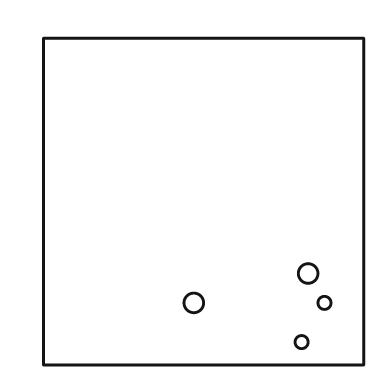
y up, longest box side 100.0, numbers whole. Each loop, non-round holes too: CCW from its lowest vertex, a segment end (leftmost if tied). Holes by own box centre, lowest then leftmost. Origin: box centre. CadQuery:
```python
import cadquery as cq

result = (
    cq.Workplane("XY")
    .moveTo(-49.0, -50.0)
    .lineTo(49.0, -50.0)
    .lineTo(49.0, 50.0)
    .lineTo(-49.0, 50.0)
    .close()
    .moveTo(30.0, -43.0)
    .circle(2.0)
    .moveTo(-3.0, -31.0)
    .circle(3.0)
    .moveTo(37.0, -31.0)
    .circle(2.0)
    .moveTo(32.0, -22.0)
    .circle(3.0)
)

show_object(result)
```